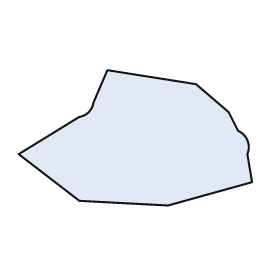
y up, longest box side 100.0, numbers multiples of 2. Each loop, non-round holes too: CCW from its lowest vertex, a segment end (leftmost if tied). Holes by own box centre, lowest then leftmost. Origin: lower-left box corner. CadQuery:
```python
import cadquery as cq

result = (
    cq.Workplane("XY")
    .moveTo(64.0, 0.0)
    .lineTo(100.0, 10.0)
    .lineTo(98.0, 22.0)
    .threePointArc((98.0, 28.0), (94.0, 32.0))
    .lineTo(90.0, 40.0)
    .lineTo(76.0, 52.0)
    .lineTo(38.0, 58.0)
    .lineTo(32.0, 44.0)
    .threePointArc((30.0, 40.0), (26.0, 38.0))
    .lineTo(0.0, 22.0)
    .lineTo(26.0, 2.0)
    .close()
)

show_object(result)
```